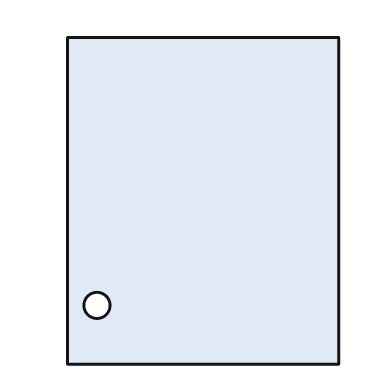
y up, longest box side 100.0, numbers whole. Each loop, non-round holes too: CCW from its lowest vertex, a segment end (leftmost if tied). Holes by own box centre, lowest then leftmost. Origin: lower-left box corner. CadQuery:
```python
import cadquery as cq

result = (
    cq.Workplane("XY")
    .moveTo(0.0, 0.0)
    .lineTo(83.0, 0.0)
    .lineTo(83.0, 100.0)
    .lineTo(0.0, 100.0)
    .close()
    .moveTo(9.0, 18.0)
    .circle(4.0)
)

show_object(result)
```